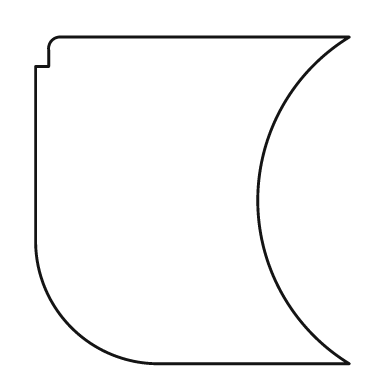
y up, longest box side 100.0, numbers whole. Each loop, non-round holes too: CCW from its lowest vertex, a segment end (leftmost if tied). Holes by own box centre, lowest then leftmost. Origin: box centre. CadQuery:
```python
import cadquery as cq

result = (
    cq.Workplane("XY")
    .moveTo(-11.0, -50.0)
    .lineTo(48.0, -50.0)
    .threePointArc((20.0, 0.0), (48.0, 50.0))
    .lineTo(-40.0, 50.0)
    .threePointArc((-43.0, 49.0), (-44.0, 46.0))
    .lineTo(-44.0, 41.0)
    .lineTo(-48.0, 41.0)
    .lineTo(-48.0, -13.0)
    .threePointArc((-37.0, -39.0), (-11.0, -50.0))
    .close()
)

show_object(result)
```